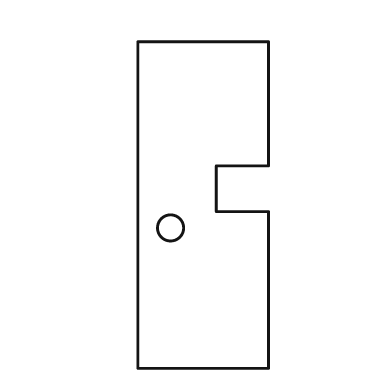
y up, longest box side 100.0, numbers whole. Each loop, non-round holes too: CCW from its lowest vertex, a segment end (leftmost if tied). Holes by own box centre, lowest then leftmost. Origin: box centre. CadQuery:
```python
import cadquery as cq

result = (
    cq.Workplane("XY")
    .moveTo(-20.0, -50.0)
    .lineTo(20.0, -50.0)
    .lineTo(20.0, -2.0)
    .lineTo(4.0, -2.0)
    .lineTo(4.0, 12.0)
    .lineTo(20.0, 12.0)
    .lineTo(20.0, 50.0)
    .lineTo(-20.0, 50.0)
    .close()
    .moveTo(-10.0, -7.0)
    .circle(4.0)
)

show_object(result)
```